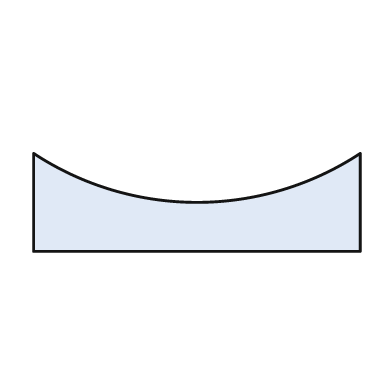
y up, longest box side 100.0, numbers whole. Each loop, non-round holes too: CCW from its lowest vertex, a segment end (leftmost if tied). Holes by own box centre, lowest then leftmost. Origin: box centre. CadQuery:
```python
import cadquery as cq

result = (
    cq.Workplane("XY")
    .moveTo(-50.0, -15.0)
    .lineTo(50.0, -15.0)
    .lineTo(50.0, 15.0)
    .threePointArc((0.0, 0.0), (-50.0, 15.0))
    .close()
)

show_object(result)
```